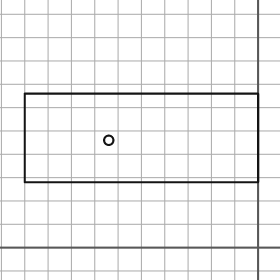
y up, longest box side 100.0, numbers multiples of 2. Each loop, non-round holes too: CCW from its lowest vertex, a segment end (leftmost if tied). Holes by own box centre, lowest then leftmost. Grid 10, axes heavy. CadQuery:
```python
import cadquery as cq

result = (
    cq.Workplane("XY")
    .moveTo(-100.0, 28.0)
    .lineTo(0.0, 28.0)
    .lineTo(0.0, 66.0)
    .lineTo(-100.0, 66.0)
    .close()
    .moveTo(-64.0, 46.0)
    .circle(2.0)
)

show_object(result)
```